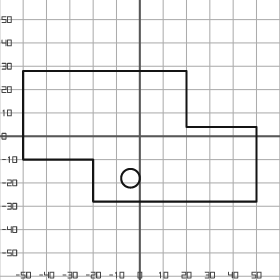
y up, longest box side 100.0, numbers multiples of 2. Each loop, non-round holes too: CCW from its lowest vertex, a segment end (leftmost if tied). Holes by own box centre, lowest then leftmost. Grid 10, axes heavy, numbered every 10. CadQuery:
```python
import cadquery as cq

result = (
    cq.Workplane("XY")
    .moveTo(-20.0, -28.0)
    .lineTo(50.0, -28.0)
    .lineTo(50.0, 4.0)
    .lineTo(20.0, 4.0)
    .lineTo(20.0, 28.0)
    .lineTo(-50.0, 28.0)
    .lineTo(-50.0, -10.0)
    .lineTo(-20.0, -10.0)
    .close()
    .moveTo(-4.0, -18.0)
    .circle(4.0)
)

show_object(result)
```